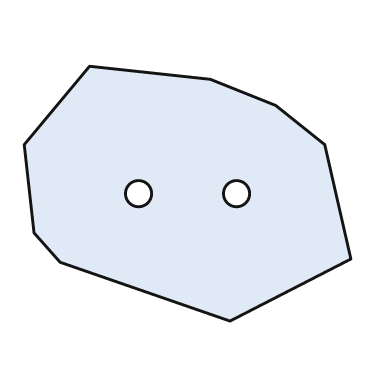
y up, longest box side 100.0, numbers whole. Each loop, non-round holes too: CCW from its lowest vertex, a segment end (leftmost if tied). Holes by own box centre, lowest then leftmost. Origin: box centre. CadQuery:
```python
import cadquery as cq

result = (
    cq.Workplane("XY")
    .moveTo(13.0, -39.0)
    .lineTo(50.0, -20.0)
    .lineTo(42.0, 15.0)
    .lineTo(27.0, 27.0)
    .lineTo(7.0, 35.0)
    .lineTo(-30.0, 39.0)
    .lineTo(-50.0, 15.0)
    .lineTo(-47.0, -12.0)
    .lineTo(-39.0, -21.0)
    .close()
    .moveTo(-15.0, 0.0)
    .circle(4.0)
    .moveTo(15.0, 0.0)
    .circle(4.0)
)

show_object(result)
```